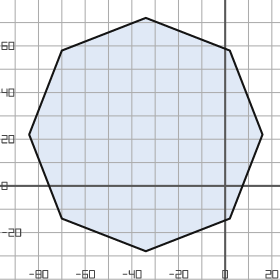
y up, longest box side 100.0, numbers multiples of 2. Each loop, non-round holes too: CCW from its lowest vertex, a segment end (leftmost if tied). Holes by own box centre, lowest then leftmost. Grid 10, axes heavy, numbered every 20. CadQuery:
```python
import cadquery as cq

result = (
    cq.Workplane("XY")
    .moveTo(-34.0, -28.0)
    .lineTo(2.0, -14.0)
    .lineTo(16.0, 22.0)
    .lineTo(2.0, 58.0)
    .lineTo(-34.0, 72.0)
    .lineTo(-70.0, 58.0)
    .lineTo(-84.0, 22.0)
    .lineTo(-70.0, -14.0)
    .close()
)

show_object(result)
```